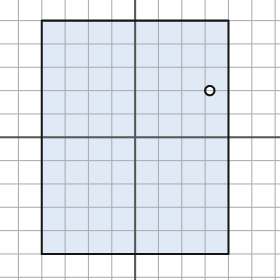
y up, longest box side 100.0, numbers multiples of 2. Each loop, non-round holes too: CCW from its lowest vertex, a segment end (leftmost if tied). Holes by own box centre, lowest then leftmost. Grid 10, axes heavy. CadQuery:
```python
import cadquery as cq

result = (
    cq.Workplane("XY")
    .moveTo(-40.0, -50.0)
    .lineTo(40.0, -50.0)
    .lineTo(40.0, 50.0)
    .lineTo(-40.0, 50.0)
    .close()
    .moveTo(32.0, 20.0)
    .circle(2.0)
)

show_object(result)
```